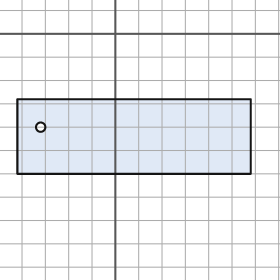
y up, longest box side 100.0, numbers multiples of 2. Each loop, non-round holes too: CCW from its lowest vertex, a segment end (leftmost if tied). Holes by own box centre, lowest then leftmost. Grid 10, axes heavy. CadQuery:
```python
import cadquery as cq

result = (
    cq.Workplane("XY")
    .moveTo(-42.0, -60.0)
    .lineTo(58.0, -60.0)
    .lineTo(58.0, -28.0)
    .lineTo(-42.0, -28.0)
    .close()
    .moveTo(-32.0, -40.0)
    .circle(2.0)
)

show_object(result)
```